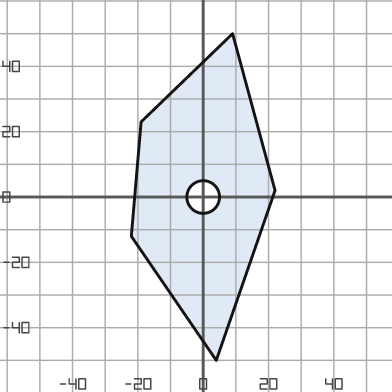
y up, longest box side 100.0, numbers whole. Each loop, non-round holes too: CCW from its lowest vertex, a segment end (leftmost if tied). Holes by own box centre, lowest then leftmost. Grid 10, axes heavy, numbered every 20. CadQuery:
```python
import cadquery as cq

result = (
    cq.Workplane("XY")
    .moveTo(4.0, -50.0)
    .lineTo(22.0, 2.0)
    .lineTo(9.0, 50.0)
    .lineTo(-19.0, 23.0)
    .lineTo(-22.0, -12.0)
    .close()
    .moveTo(0.0, 0.0)
    .circle(5.0)
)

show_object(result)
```